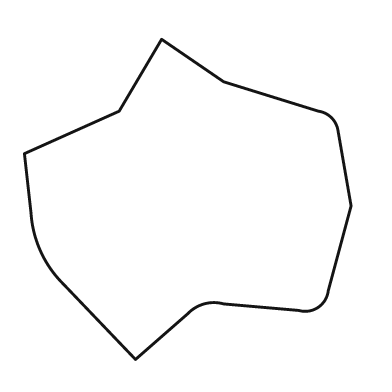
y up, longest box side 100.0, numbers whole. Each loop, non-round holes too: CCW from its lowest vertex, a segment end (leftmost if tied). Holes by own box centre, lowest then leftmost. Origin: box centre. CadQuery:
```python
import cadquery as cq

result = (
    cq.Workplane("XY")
    .moveTo(-16.0, -49.0)
    .lineTo(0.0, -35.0)
    .threePointArc((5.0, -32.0), (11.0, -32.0))
    .lineTo(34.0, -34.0)
    .threePointArc((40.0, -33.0), (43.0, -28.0))
    .lineTo(50.0, -2.0)
    .lineTo(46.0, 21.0)
    .threePointArc((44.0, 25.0), (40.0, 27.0))
    .lineTo(11.0, 36.0)
    .lineTo(-8.0, 49.0)
    .lineTo(-21.0, 27.0)
    .lineTo(-50.0, 14.0)
    .lineTo(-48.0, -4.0)
    .threePointArc((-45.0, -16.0), (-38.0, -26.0))
    .close()
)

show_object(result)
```